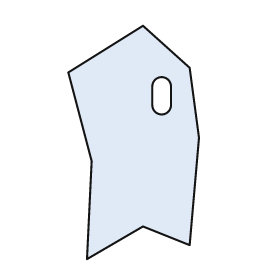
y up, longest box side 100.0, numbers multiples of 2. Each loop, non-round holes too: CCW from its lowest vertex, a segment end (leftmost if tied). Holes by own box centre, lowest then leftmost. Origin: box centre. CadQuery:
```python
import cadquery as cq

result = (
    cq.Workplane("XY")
    .moveTo(-20.0, -50.0)
    .lineTo(4.0, -36.0)
    .lineTo(24.0, -44.0)
    .lineTo(28.0, 2.0)
    .lineTo(24.0, 32.0)
    .lineTo(4.0, 50.0)
    .lineTo(-28.0, 30.0)
    .lineTo(-18.0, -8.0)
    .close()
    .moveTo(8.0, 16.0)
    .threePointArc((12.0, 12.0), (16.0, 16.0))
    .lineTo(16.0, 24.0)
    .threePointArc((12.0, 28.0), (8.0, 24.0))
    .close()
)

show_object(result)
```